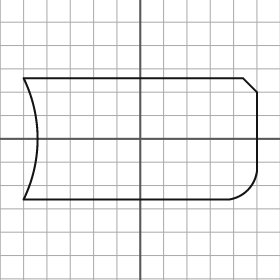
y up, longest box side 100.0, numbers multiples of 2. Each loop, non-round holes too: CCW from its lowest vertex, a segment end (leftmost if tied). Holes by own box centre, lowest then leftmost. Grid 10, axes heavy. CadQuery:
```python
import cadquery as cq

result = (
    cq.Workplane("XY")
    .moveTo(-50.0, -26.0)
    .lineTo(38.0, -26.0)
    .threePointArc((46.0, -22.0), (50.0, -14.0))
    .lineTo(50.0, 20.0)
    .lineTo(44.0, 26.0)
    .lineTo(-50.0, 26.0)
    .threePointArc((-44.0, 0.0), (-50.0, -26.0))
    .close()
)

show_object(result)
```